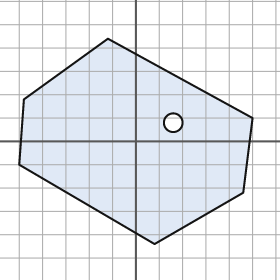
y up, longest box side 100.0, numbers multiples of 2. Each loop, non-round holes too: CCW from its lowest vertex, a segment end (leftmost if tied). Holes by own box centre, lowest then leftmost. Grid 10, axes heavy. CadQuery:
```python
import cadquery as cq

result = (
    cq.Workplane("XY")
    .moveTo(8.0, -44.0)
    .lineTo(46.0, -22.0)
    .lineTo(50.0, 10.0)
    .lineTo(-12.0, 44.0)
    .lineTo(-48.0, 18.0)
    .lineTo(-50.0, -10.0)
    .close()
    .moveTo(16.0, 8.0)
    .circle(4.0)
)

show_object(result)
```